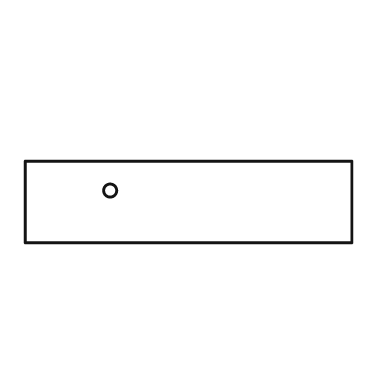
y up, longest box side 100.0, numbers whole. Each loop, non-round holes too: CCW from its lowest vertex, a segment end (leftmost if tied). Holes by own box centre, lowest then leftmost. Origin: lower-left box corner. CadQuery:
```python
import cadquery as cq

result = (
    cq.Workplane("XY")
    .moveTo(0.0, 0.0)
    .lineTo(100.0, 0.0)
    .lineTo(100.0, 25.0)
    .lineTo(0.0, 25.0)
    .close()
    .moveTo(26.0, 16.0)
    .circle(2.0)
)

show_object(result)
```